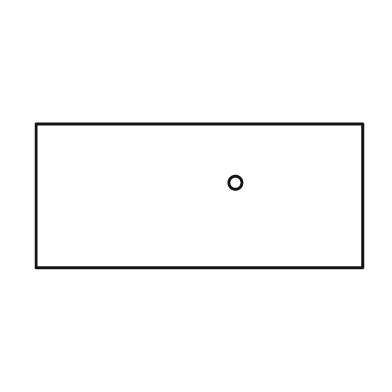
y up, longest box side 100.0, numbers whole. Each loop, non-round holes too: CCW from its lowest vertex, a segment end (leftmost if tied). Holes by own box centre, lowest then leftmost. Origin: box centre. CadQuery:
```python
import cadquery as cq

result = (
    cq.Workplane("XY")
    .moveTo(-50.0, -22.0)
    .lineTo(50.0, -22.0)
    .lineTo(50.0, 22.0)
    .lineTo(-50.0, 22.0)
    .close()
    .moveTo(11.0, 4.0)
    .circle(2.0)
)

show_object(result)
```